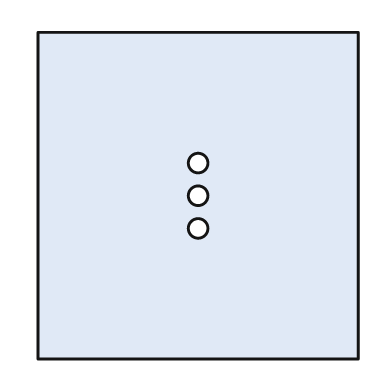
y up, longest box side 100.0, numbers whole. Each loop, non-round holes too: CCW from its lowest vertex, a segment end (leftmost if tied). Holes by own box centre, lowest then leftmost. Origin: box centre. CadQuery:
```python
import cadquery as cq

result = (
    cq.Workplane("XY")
    .moveTo(-49.0, -50.0)
    .lineTo(49.0, -50.0)
    .lineTo(49.0, 50.0)
    .lineTo(-49.0, 50.0)
    .close()
    .moveTo(0.0, -10.0)
    .circle(3.0)
    .moveTo(0.0, 0.0)
    .circle(3.0)
    .moveTo(0.0, 10.0)
    .circle(3.0)
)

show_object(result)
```